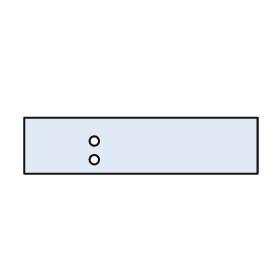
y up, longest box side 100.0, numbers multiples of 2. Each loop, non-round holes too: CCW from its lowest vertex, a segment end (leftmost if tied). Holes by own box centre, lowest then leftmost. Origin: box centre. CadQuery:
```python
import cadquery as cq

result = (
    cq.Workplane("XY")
    .moveTo(-50.0, -12.0)
    .lineTo(50.0, -12.0)
    .lineTo(50.0, 12.0)
    .lineTo(-50.0, 12.0)
    .close()
    .moveTo(-20.0, -6.0)
    .circle(2.0)
    .moveTo(-20.0, 2.0)
    .circle(2.0)
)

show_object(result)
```